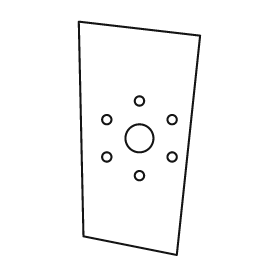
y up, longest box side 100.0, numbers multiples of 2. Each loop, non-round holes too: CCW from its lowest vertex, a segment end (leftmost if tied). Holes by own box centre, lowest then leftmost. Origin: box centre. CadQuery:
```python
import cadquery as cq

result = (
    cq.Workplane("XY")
    .moveTo(16.0, -50.0)
    .lineTo(26.0, 44.0)
    .lineTo(-26.0, 50.0)
    .lineTo(-24.0, -42.0)
    .close()
    .moveTo(0.0, -16.0)
    .circle(2.0)
    .moveTo(-14.0, -8.0)
    .circle(2.0)
    .moveTo(14.0, -8.0)
    .circle(2.0)
    .moveTo(0.0, 0.0)
    .circle(6.0)
    .moveTo(-14.0, 8.0)
    .circle(2.0)
    .moveTo(14.0, 8.0)
    .circle(2.0)
    .moveTo(0.0, 16.0)
    .circle(2.0)
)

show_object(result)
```